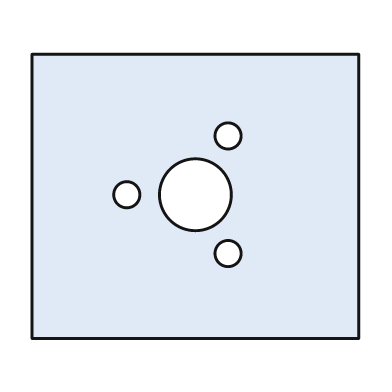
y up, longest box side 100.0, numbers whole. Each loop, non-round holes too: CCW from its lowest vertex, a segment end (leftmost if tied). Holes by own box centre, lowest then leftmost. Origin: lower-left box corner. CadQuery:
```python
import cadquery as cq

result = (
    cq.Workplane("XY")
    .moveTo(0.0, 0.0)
    .lineTo(100.0, 0.0)
    .lineTo(100.0, 87.0)
    .lineTo(0.0, 87.0)
    .close()
    .moveTo(60.0, 26.0)
    .circle(4.0)
    .moveTo(29.0, 44.0)
    .circle(4.0)
    .moveTo(50.0, 44.0)
    .circle(11.0)
    .moveTo(60.0, 62.0)
    .circle(4.0)
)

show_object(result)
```